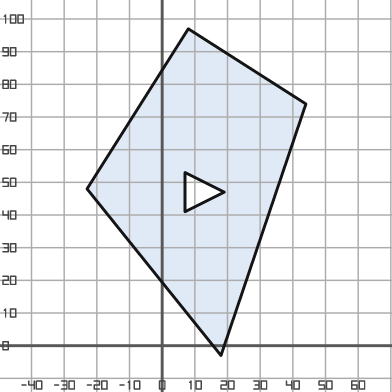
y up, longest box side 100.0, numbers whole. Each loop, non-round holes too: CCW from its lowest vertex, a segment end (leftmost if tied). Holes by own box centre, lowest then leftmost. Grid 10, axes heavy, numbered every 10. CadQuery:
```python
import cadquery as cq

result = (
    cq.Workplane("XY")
    .moveTo(18.0, -3.0)
    .lineTo(44.0, 74.0)
    .lineTo(8.0, 97.0)
    .lineTo(-23.0, 48.0)
    .close()
    .moveTo(7.0, 41.0)
    .lineTo(19.0, 47.0)
    .lineTo(7.0, 53.0)
    .close()
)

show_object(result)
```